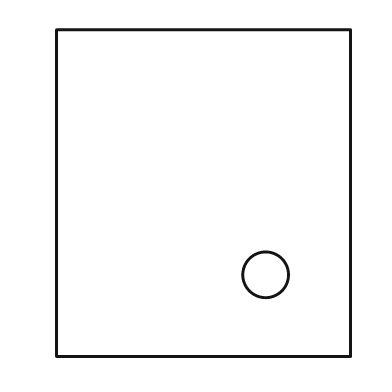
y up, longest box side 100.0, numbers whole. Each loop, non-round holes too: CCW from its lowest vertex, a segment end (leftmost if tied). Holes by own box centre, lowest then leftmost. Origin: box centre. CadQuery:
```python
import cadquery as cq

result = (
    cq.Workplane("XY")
    .moveTo(-45.0, -50.0)
    .lineTo(45.0, -50.0)
    .lineTo(45.0, 50.0)
    .lineTo(-45.0, 50.0)
    .close()
    .moveTo(19.0, -25.0)
    .circle(7.0)
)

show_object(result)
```